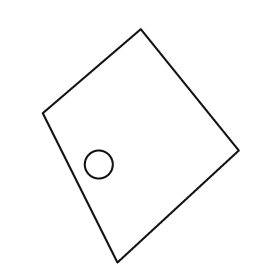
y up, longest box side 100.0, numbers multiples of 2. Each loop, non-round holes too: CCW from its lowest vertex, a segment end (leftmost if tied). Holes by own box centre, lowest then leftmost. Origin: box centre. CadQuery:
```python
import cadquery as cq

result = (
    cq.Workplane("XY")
    .moveTo(-10.0, -50.0)
    .lineTo(42.0, -2.0)
    .lineTo(0.0, 50.0)
    .lineTo(-42.0, 14.0)
    .close()
    .moveTo(-18.0, -8.0)
    .circle(6.0)
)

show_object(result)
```